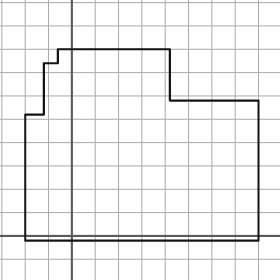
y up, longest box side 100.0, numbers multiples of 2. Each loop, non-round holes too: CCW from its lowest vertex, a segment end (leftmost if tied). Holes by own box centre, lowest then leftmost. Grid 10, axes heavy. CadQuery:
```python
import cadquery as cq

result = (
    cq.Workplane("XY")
    .moveTo(-20.0, -2.0)
    .lineTo(80.0, -2.0)
    .lineTo(80.0, 58.0)
    .lineTo(42.0, 58.0)
    .lineTo(42.0, 80.0)
    .lineTo(-6.0, 80.0)
    .lineTo(-6.0, 74.0)
    .lineTo(-12.0, 74.0)
    .lineTo(-12.0, 52.0)
    .lineTo(-20.0, 52.0)
    .close()
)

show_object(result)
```